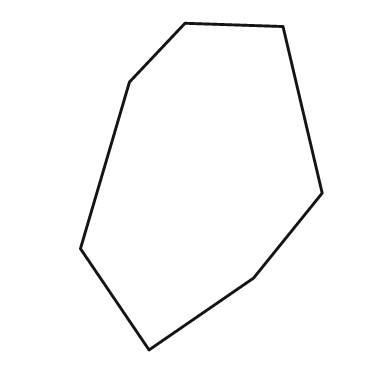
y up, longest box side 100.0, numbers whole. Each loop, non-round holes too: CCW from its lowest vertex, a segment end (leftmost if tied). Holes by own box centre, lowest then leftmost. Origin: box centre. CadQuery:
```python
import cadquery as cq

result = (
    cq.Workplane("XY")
    .moveTo(-16.0, -50.0)
    .lineTo(16.0, -28.0)
    .lineTo(37.0, -2.0)
    .lineTo(25.0, 49.0)
    .lineTo(-5.0, 50.0)
    .lineTo(-22.0, 32.0)
    .lineTo(-37.0, -19.0)
    .close()
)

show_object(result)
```